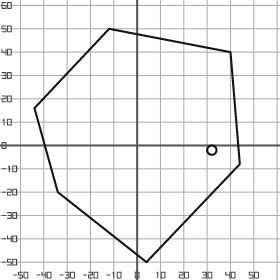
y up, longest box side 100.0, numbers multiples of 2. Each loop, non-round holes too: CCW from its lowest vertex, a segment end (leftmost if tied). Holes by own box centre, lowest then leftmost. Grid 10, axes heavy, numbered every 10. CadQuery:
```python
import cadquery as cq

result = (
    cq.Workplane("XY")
    .moveTo(4.0, -50.0)
    .lineTo(44.0, -8.0)
    .lineTo(40.0, 40.0)
    .lineTo(-12.0, 50.0)
    .lineTo(-44.0, 16.0)
    .lineTo(-34.0, -20.0)
    .close()
    .moveTo(32.0, -2.0)
    .circle(2.0)
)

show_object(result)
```